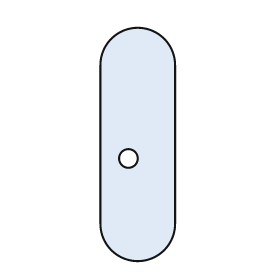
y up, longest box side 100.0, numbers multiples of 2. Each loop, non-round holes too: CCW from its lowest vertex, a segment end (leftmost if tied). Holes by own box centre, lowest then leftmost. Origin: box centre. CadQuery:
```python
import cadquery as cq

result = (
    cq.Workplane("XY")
    .moveTo(-16.0, -34.0)
    .threePointArc((0.0, -50.0), (16.0, -34.0))
    .lineTo(16.0, 34.0)
    .threePointArc((0.0, 50.0), (-16.0, 34.0))
    .close()
    .moveTo(-4.0, -6.0)
    .circle(4.0)
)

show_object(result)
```